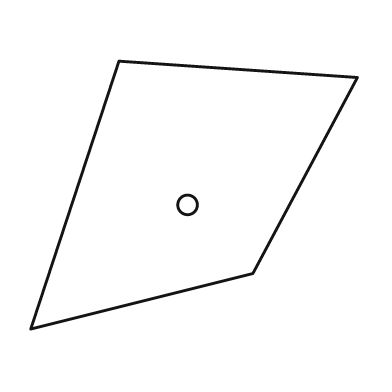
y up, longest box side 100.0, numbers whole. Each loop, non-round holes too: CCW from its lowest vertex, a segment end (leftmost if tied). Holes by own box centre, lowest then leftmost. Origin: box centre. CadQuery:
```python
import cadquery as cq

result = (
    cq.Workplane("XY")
    .moveTo(-50.0, -41.0)
    .lineTo(18.0, -24.0)
    .lineTo(50.0, 36.0)
    .lineTo(-23.0, 41.0)
    .close()
    .moveTo(-2.0, -3.0)
    .circle(3.0)
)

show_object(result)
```